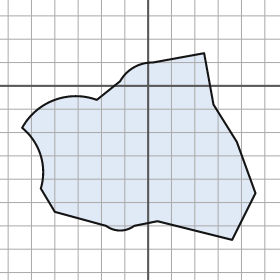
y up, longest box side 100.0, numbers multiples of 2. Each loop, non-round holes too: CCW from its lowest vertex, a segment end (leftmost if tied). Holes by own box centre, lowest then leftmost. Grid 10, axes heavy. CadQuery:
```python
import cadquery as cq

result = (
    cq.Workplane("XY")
    .moveTo(36.0, -66.0)
    .lineTo(46.0, -46.0)
    .lineTo(38.0, -24.0)
    .lineTo(28.0, -8.0)
    .lineTo(24.0, 14.0)
    .lineTo(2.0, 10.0)
    .threePointArc((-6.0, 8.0), (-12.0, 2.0))
    .lineTo(-22.0, -6.0)
    .threePointArc((-40.0, -6.0), (-54.0, -18.0))
    .threePointArc((-46.0, -30.0), (-46.0, -44.0))
    .lineTo(-40.0, -54.0)
    .lineTo(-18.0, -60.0)
    .threePointArc((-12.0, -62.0), (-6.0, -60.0))
    .lineTo(4.0, -58.0)
    .close()
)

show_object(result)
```